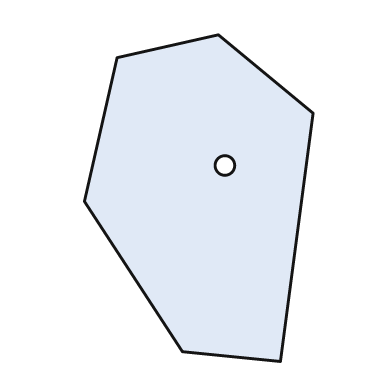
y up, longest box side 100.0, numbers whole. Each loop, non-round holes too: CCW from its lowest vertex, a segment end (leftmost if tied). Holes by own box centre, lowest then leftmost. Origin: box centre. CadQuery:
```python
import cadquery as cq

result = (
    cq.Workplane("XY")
    .moveTo(25.0, -50.0)
    .lineTo(35.0, 26.0)
    .lineTo(6.0, 50.0)
    .lineTo(-25.0, 43.0)
    .lineTo(-35.0, -1.0)
    .lineTo(-5.0, -47.0)
    .close()
    .moveTo(8.0, 10.0)
    .circle(3.0)
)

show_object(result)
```